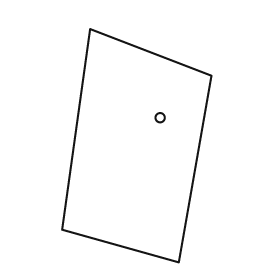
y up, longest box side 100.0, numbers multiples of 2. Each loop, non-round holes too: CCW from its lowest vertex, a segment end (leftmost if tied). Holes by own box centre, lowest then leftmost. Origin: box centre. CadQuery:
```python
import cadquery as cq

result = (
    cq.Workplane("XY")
    .moveTo(18.0, -50.0)
    .lineTo(32.0, 30.0)
    .lineTo(-20.0, 50.0)
    .lineTo(-32.0, -36.0)
    .close()
    .moveTo(10.0, 12.0)
    .circle(2.0)
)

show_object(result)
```